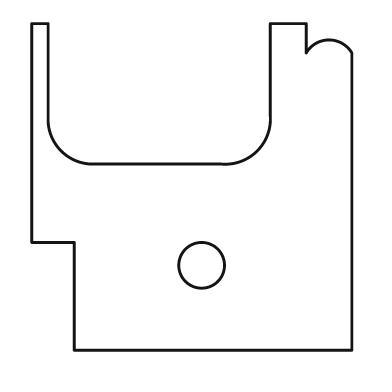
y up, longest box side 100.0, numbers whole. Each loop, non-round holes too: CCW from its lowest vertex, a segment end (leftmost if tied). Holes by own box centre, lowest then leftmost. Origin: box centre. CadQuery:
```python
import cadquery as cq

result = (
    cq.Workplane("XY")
    .moveTo(-36.0, -50.0)
    .lineTo(49.0, -50.0)
    .lineTo(49.0, 41.0)
    .threePointArc((42.0, 45.0), (35.0, 41.0))
    .lineTo(35.0, 50.0)
    .lineTo(24.0, 50.0)
    .lineTo(24.0, 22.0)
    .threePointArc((20.0, 11.0), (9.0, 7.0))
    .lineTo(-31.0, 7.0)
    .threePointArc((-40.0, 11.0), (-44.0, 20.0))
    .lineTo(-44.0, 50.0)
    .lineTo(-49.0, 50.0)
    .lineTo(-49.0, -17.0)
    .lineTo(-36.0, -17.0)
    .close()
    .moveTo(3.0, -24.0)
    .circle(7.0)
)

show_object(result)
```